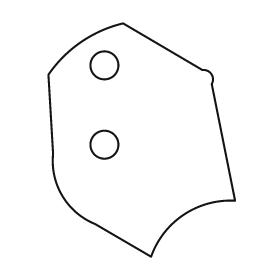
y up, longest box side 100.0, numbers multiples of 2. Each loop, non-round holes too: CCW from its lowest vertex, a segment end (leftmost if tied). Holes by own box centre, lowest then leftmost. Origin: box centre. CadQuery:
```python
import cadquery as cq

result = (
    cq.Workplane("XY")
    .moveTo(4.0, -50.0)
    .threePointArc((18.0, -32.0), (40.0, -26.0))
    .lineTo(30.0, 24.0)
    .threePointArc((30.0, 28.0), (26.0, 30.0))
    .lineTo(-8.0, 50.0)
    .threePointArc((-26.0, 42.0), (-40.0, 28.0))
    .lineTo(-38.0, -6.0)
    .threePointArc((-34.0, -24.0), (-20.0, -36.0))
    .close()
    .moveTo(-16.0, -2.0)
    .circle(6.0)
    .moveTo(-16.0, 32.0)
    .circle(6.0)
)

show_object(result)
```